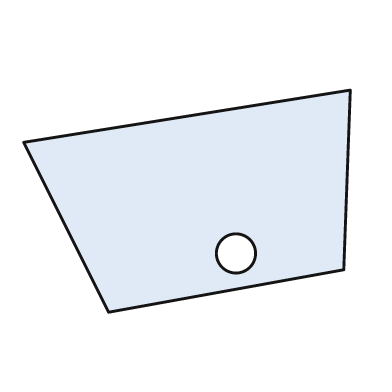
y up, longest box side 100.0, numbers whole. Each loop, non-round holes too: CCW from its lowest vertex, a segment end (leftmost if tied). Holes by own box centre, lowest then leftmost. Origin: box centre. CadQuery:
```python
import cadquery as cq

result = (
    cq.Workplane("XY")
    .moveTo(-24.0, -34.0)
    .lineTo(48.0, -21.0)
    .lineTo(50.0, 34.0)
    .lineTo(-50.0, 18.0)
    .close()
    .moveTo(15.0, -16.0)
    .circle(6.0)
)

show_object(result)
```